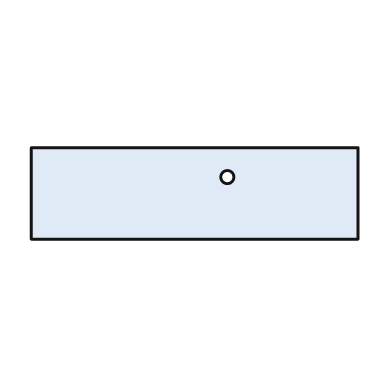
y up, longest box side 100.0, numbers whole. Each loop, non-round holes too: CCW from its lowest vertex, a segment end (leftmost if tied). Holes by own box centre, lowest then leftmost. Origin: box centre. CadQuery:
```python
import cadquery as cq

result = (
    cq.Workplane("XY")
    .moveTo(-50.0, -14.0)
    .lineTo(50.0, -14.0)
    .lineTo(50.0, 14.0)
    .lineTo(-50.0, 14.0)
    .close()
    .moveTo(10.0, 5.0)
    .circle(2.0)
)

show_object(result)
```